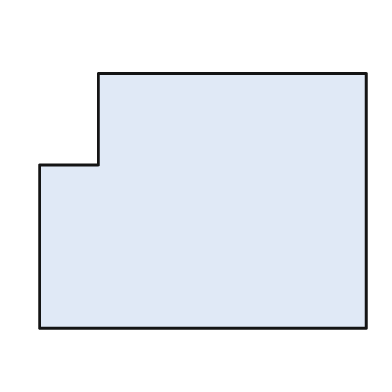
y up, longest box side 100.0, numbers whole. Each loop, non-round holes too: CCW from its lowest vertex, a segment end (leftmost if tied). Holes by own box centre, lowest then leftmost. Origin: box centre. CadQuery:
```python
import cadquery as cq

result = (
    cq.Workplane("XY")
    .moveTo(-50.0, -39.0)
    .lineTo(50.0, -39.0)
    .lineTo(50.0, 39.0)
    .lineTo(-32.0, 39.0)
    .lineTo(-32.0, 11.0)
    .lineTo(-50.0, 11.0)
    .close()
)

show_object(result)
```